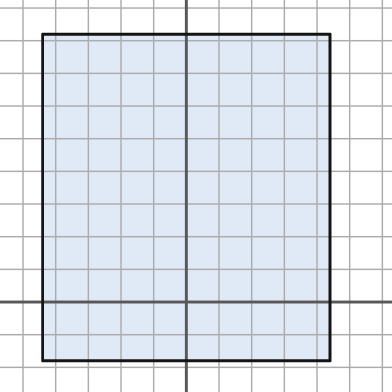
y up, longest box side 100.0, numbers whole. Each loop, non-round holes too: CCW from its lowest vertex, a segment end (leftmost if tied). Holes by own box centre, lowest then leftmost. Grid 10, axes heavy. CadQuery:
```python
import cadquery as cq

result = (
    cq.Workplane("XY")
    .moveTo(-44.0, -18.0)
    .lineTo(44.0, -18.0)
    .lineTo(44.0, 82.0)
    .lineTo(-44.0, 82.0)
    .close()
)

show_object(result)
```